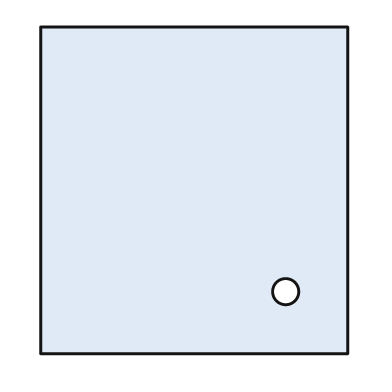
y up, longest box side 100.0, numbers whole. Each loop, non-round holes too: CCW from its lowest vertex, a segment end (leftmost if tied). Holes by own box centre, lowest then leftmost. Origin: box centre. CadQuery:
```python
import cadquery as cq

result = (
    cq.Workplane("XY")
    .moveTo(-47.0, -50.0)
    .lineTo(47.0, -50.0)
    .lineTo(47.0, 50.0)
    .lineTo(-47.0, 50.0)
    .close()
    .moveTo(28.0, -31.0)
    .circle(4.0)
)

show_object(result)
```